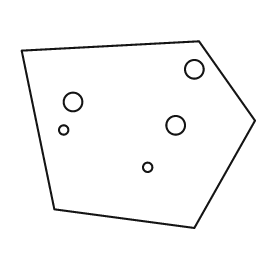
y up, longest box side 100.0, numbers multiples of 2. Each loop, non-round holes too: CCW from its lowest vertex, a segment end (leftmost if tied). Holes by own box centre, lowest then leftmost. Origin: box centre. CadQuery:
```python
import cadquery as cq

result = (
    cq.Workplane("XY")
    .moveTo(24.0, -40.0)
    .lineTo(50.0, 6.0)
    .lineTo(26.0, 40.0)
    .lineTo(-50.0, 36.0)
    .lineTo(-36.0, -32.0)
    .close()
    .moveTo(4.0, -14.0)
    .circle(2.0)
    .moveTo(-32.0, 2.0)
    .circle(2.0)
    .moveTo(16.0, 4.0)
    .circle(4.0)
    .moveTo(-28.0, 14.0)
    .circle(4.0)
    .moveTo(24.0, 28.0)
    .circle(4.0)
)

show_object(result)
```